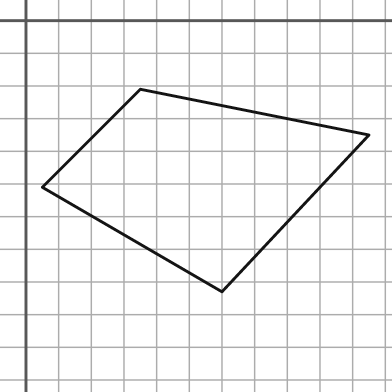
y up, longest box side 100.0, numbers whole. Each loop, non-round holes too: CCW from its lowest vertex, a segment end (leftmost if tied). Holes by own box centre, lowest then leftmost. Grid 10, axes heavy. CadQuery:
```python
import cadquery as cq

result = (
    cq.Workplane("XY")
    .moveTo(60.0, -83.0)
    .lineTo(105.0, -35.0)
    .lineTo(35.0, -21.0)
    .lineTo(5.0, -51.0)
    .close()
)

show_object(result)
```